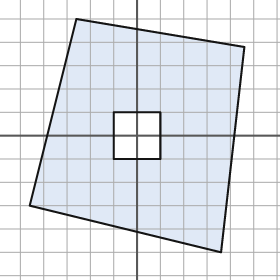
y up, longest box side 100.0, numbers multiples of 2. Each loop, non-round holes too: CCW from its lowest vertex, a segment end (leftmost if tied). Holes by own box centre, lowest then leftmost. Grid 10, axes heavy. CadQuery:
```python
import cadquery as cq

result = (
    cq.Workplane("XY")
    .moveTo(36.0, -50.0)
    .lineTo(46.0, 38.0)
    .lineTo(-26.0, 50.0)
    .lineTo(-46.0, -30.0)
    .close()
    .moveTo(-10.0, -10.0)
    .lineTo(10.0, -10.0)
    .lineTo(10.0, 10.0)
    .lineTo(-10.0, 10.0)
    .close()
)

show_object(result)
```